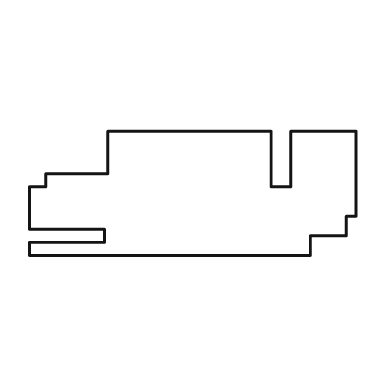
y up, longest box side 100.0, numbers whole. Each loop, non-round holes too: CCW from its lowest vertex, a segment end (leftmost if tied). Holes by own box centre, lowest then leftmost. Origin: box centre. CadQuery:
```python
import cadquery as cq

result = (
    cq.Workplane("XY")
    .moveTo(-50.0, -19.0)
    .lineTo(36.0, -19.0)
    .lineTo(36.0, -13.0)
    .lineTo(47.0, -13.0)
    .lineTo(47.0, -7.0)
    .lineTo(50.0, -7.0)
    .lineTo(50.0, 19.0)
    .lineTo(30.0, 19.0)
    .lineTo(30.0, 2.0)
    .lineTo(24.0, 2.0)
    .lineTo(24.0, 19.0)
    .lineTo(-26.0, 19.0)
    .lineTo(-26.0, 6.0)
    .lineTo(-45.0, 6.0)
    .lineTo(-45.0, 2.0)
    .lineTo(-50.0, 2.0)
    .lineTo(-50.0, -11.0)
    .lineTo(-27.0, -11.0)
    .lineTo(-27.0, -15.0)
    .lineTo(-50.0, -15.0)
    .close()
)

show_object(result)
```